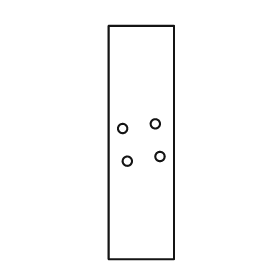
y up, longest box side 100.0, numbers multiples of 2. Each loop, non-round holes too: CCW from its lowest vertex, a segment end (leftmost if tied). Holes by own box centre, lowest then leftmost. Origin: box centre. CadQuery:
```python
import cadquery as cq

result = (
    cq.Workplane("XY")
    .moveTo(-14.0, -50.0)
    .lineTo(14.0, -50.0)
    .lineTo(14.0, 50.0)
    .lineTo(-14.0, 50.0)
    .close()
    .moveTo(-6.0, -8.0)
    .circle(2.0)
    .moveTo(8.0, -6.0)
    .circle(2.0)
    .moveTo(-8.0, 6.0)
    .circle(2.0)
    .moveTo(6.0, 8.0)
    .circle(2.0)
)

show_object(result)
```